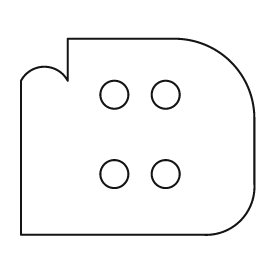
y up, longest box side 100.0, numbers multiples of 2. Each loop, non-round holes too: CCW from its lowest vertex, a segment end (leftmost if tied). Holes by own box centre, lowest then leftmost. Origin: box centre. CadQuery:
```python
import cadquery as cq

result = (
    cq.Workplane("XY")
    .moveTo(-50.0, -42.0)
    .lineTo(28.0, -42.0)
    .threePointArc((44.0, -36.0), (50.0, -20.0))
    .lineTo(50.0, 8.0)
    .threePointArc((40.0, 32.0), (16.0, 42.0))
    .lineTo(-30.0, 42.0)
    .lineTo(-30.0, 24.0)
    .threePointArc((-40.0, 30.0), (-50.0, 24.0))
    .close()
    .moveTo(-10.0, -16.0)
    .circle(6.0)
    .moveTo(12.0, -16.0)
    .circle(6.0)
    .moveTo(-10.0, 18.0)
    .circle(6.0)
    .moveTo(12.0, 18.0)
    .circle(6.0)
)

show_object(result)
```